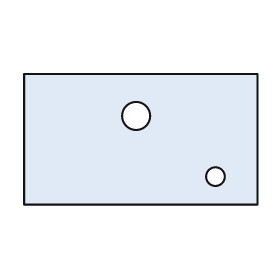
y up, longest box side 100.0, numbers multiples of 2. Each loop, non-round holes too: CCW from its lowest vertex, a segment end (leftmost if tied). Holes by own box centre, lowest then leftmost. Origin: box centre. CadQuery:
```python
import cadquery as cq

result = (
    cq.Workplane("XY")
    .moveTo(-50.0, -28.0)
    .lineTo(50.0, -28.0)
    .lineTo(50.0, 28.0)
    .lineTo(-50.0, 28.0)
    .close()
    .moveTo(32.0, -16.0)
    .circle(4.0)
    .moveTo(-2.0, 10.0)
    .circle(6.0)
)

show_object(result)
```